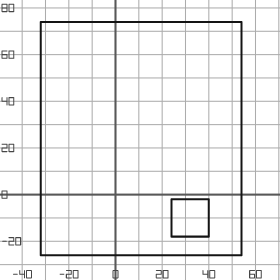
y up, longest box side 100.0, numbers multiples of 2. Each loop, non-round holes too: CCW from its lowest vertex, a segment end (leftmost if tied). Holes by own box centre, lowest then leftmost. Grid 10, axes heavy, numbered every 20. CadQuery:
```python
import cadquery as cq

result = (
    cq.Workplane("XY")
    .moveTo(-32.0, -26.0)
    .lineTo(54.0, -26.0)
    .lineTo(54.0, 74.0)
    .lineTo(-32.0, 74.0)
    .close()
    .moveTo(24.0, -18.0)
    .lineTo(40.0, -18.0)
    .lineTo(40.0, -2.0)
    .lineTo(24.0, -2.0)
    .close()
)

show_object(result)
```